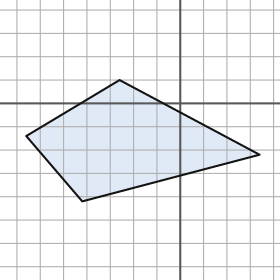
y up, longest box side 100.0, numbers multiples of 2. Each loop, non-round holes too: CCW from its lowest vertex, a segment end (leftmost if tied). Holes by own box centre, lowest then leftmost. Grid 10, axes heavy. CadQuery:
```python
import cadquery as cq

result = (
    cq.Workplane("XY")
    .moveTo(-42.0, -42.0)
    .lineTo(34.0, -22.0)
    .lineTo(-26.0, 10.0)
    .lineTo(-66.0, -14.0)
    .close()
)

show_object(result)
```